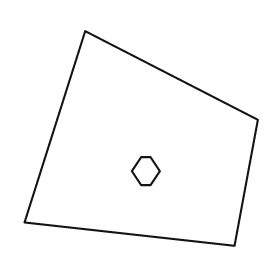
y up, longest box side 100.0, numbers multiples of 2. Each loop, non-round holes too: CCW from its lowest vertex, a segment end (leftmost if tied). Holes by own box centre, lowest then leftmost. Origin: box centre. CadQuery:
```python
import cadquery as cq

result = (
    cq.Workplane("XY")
    .moveTo(40.0, -46.0)
    .lineTo(50.0, 8.0)
    .lineTo(-24.0, 46.0)
    .lineTo(-50.0, -36.0)
    .close()
    .moveTo(0.0, -20.0)
    .lineTo(4.0, -20.0)
    .lineTo(8.0, -14.0)
    .lineTo(4.0, -8.0)
    .lineTo(0.0, -8.0)
    .lineTo(-4.0, -14.0)
    .close()
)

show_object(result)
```